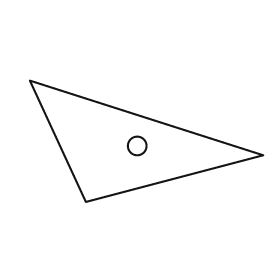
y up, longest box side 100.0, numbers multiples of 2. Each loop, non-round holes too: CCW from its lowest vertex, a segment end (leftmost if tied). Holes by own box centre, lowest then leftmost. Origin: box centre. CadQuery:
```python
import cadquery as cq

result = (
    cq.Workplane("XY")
    .moveTo(-26.0, -26.0)
    .lineTo(50.0, -6.0)
    .lineTo(-50.0, 26.0)
    .close()
    .moveTo(-4.0, -2.0)
    .circle(4.0)
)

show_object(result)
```